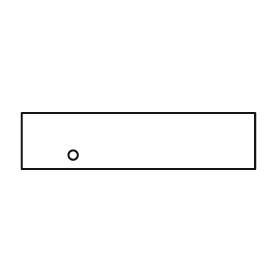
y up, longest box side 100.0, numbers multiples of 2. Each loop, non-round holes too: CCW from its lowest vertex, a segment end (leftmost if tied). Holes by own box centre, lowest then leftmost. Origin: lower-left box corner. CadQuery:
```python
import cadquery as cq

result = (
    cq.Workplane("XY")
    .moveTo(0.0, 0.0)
    .lineTo(100.0, 0.0)
    .lineTo(100.0, 24.0)
    .lineTo(0.0, 24.0)
    .close()
    .moveTo(22.0, 6.0)
    .circle(2.0)
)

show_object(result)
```